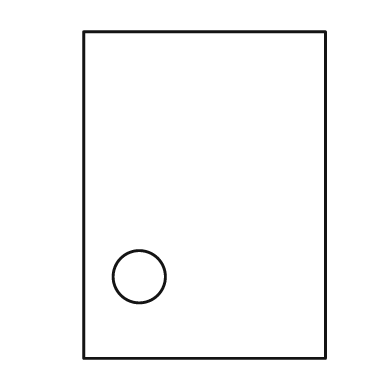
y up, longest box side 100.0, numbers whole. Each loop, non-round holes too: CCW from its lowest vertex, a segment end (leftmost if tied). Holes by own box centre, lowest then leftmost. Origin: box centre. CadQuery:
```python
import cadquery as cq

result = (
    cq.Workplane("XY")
    .moveTo(-37.0, -50.0)
    .lineTo(37.0, -50.0)
    .lineTo(37.0, 50.0)
    .lineTo(-37.0, 50.0)
    .close()
    .moveTo(-20.0, -25.0)
    .circle(8.0)
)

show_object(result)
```